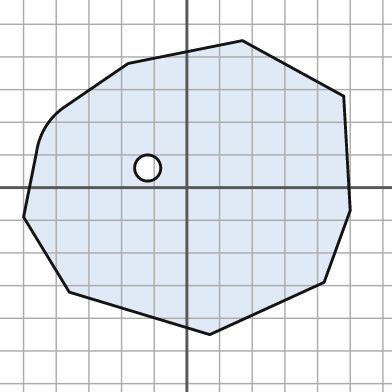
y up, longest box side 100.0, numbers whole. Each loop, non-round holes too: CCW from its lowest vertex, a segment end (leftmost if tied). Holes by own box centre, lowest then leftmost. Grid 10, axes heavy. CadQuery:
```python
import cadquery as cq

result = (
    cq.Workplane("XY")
    .moveTo(7.0, -45.0)
    .lineTo(42.0, -29.0)
    .lineTo(50.0, -7.0)
    .lineTo(48.0, 28.0)
    .lineTo(17.0, 45.0)
    .lineTo(-18.0, 38.0)
    .lineTo(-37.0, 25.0)
    .threePointArc((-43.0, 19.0), (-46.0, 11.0))
    .lineTo(-50.0, -9.0)
    .lineTo(-36.0, -32.0)
    .close()
    .moveTo(-12.0, 6.0)
    .circle(4.0)
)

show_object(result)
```